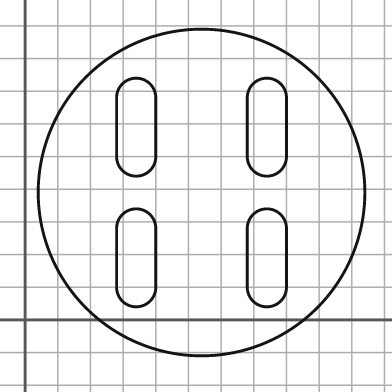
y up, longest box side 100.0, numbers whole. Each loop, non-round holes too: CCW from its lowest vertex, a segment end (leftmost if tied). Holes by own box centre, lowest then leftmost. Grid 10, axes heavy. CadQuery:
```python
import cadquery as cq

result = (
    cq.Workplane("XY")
    .moveTo(54.0, 39.0)
    .circle(50.0)
    .moveTo(28.0, 10.0)
    .threePointArc((34.0, 4.0), (40.0, 10.0))
    .lineTo(40.0, 28.0)
    .threePointArc((34.0, 34.0), (28.0, 28.0))
    .close()
    .moveTo(68.0, 10.0)
    .threePointArc((74.0, 4.0), (80.0, 10.0))
    .lineTo(80.0, 28.0)
    .threePointArc((74.0, 34.0), (68.0, 28.0))
    .close()
    .moveTo(28.0, 50.0)
    .threePointArc((34.0, 44.0), (40.0, 50.0))
    .lineTo(40.0, 68.0)
    .threePointArc((34.0, 74.0), (28.0, 68.0))
    .close()
    .moveTo(68.0, 50.0)
    .threePointArc((74.0, 44.0), (80.0, 50.0))
    .lineTo(80.0, 68.0)
    .threePointArc((74.0, 74.0), (68.0, 68.0))
    .close()
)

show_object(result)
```